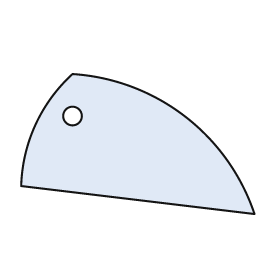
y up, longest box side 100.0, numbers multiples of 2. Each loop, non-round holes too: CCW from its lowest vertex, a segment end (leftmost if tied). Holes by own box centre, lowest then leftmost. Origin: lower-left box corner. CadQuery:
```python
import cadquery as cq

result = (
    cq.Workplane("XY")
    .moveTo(100.0, 0.0)
    .threePointArc((70.0, 42.0), (22.0, 60.0))
    .threePointArc((6.0, 38.0), (0.0, 12.0))
    .close()
    .moveTo(22.0, 42.0)
    .circle(4.0)
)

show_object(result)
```